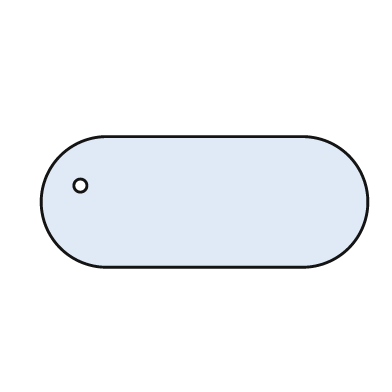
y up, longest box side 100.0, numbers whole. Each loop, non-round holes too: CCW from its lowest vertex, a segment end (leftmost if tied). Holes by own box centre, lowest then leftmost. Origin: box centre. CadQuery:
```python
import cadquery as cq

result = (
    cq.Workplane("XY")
    .moveTo(-30.0, -20.0)
    .lineTo(30.0, -20.0)
    .threePointArc((50.0, 0.0), (30.0, 20.0))
    .lineTo(-30.0, 20.0)
    .threePointArc((-50.0, 0.0), (-30.0, -20.0))
    .close()
    .moveTo(-38.0, 5.0)
    .circle(2.0)
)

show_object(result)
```